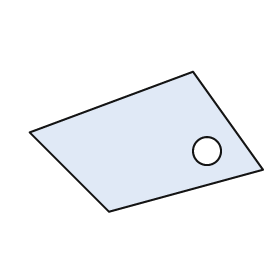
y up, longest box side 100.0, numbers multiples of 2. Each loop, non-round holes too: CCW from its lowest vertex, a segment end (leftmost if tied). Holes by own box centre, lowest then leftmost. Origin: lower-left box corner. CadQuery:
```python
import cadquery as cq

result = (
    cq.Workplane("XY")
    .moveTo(34.0, 0.0)
    .lineTo(100.0, 18.0)
    .lineTo(70.0, 60.0)
    .lineTo(0.0, 34.0)
    .close()
    .moveTo(76.0, 26.0)
    .circle(6.0)
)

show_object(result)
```